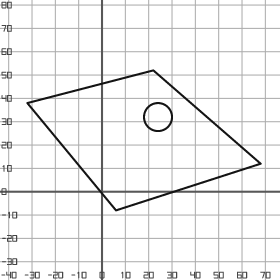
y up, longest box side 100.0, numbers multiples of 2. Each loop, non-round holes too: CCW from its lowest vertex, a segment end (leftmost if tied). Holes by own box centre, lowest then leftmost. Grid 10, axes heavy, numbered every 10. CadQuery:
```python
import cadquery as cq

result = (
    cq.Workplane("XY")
    .moveTo(6.0, -8.0)
    .lineTo(68.0, 12.0)
    .lineTo(22.0, 52.0)
    .lineTo(-32.0, 38.0)
    .close()
    .moveTo(24.0, 32.0)
    .circle(6.0)
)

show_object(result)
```